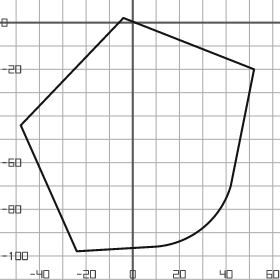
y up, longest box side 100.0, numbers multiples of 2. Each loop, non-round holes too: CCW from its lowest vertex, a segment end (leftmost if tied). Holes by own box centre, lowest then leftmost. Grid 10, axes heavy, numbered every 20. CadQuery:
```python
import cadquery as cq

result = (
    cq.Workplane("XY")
    .moveTo(-24.0, -98.0)
    .lineTo(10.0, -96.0)
    .threePointArc((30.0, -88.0), (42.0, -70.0))
    .lineTo(52.0, -20.0)
    .lineTo(-4.0, 2.0)
    .lineTo(-48.0, -44.0)
    .close()
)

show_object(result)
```